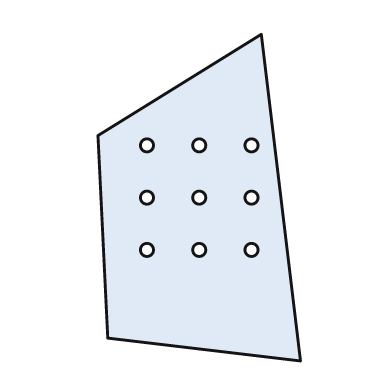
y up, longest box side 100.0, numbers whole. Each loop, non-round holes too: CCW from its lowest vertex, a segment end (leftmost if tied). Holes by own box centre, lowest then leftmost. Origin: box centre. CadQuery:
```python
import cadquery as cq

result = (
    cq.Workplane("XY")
    .moveTo(31.0, -50.0)
    .lineTo(19.0, 50.0)
    .lineTo(-31.0, 19.0)
    .lineTo(-28.0, -43.0)
    .close()
    .moveTo(-16.0, -16.0)
    .circle(2.0)
    .moveTo(0.0, -16.0)
    .circle(2.0)
    .moveTo(16.0, -16.0)
    .circle(2.0)
    .moveTo(-16.0, 0.0)
    .circle(2.0)
    .moveTo(0.0, 0.0)
    .circle(2.0)
    .moveTo(16.0, 0.0)
    .circle(2.0)
    .moveTo(-16.0, 16.0)
    .circle(2.0)
    .moveTo(0.0, 16.0)
    .circle(2.0)
    .moveTo(16.0, 16.0)
    .circle(2.0)
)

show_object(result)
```